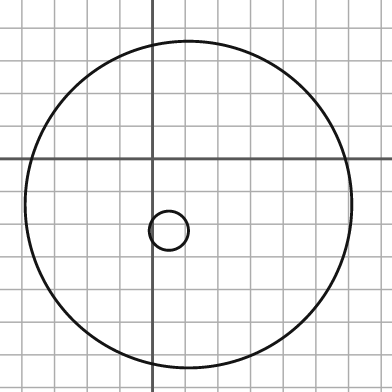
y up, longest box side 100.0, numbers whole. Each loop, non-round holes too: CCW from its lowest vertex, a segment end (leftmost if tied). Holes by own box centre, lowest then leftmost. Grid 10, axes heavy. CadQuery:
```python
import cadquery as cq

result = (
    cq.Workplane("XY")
    .moveTo(11.0, -14.0)
    .circle(50.0)
    .moveTo(5.0, -22.0)
    .circle(6.0)
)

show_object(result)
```